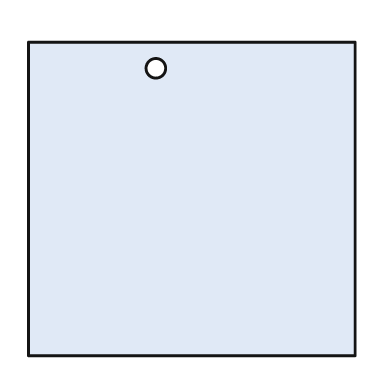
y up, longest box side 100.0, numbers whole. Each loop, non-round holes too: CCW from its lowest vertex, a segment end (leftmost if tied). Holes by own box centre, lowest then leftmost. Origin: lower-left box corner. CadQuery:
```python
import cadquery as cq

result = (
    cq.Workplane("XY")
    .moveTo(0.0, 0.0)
    .lineTo(100.0, 0.0)
    .lineTo(100.0, 96.0)
    .lineTo(0.0, 96.0)
    .close()
    .moveTo(39.0, 88.0)
    .circle(3.0)
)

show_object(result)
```